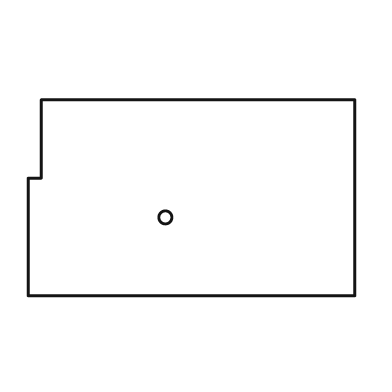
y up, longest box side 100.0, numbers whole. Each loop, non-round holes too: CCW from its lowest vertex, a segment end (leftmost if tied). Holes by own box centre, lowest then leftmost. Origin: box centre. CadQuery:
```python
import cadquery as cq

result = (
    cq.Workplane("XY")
    .moveTo(-50.0, -30.0)
    .lineTo(50.0, -30.0)
    .lineTo(50.0, 30.0)
    .lineTo(-46.0, 30.0)
    .lineTo(-46.0, 6.0)
    .lineTo(-50.0, 6.0)
    .close()
    .moveTo(-8.0, -6.0)
    .circle(2.0)
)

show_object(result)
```